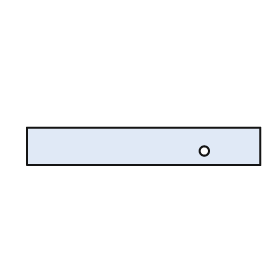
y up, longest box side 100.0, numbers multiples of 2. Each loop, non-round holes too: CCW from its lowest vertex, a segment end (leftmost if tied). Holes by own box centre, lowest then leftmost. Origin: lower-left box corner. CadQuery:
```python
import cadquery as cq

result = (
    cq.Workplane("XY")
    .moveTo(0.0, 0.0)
    .lineTo(100.0, 0.0)
    .lineTo(100.0, 16.0)
    .lineTo(0.0, 16.0)
    .close()
    .moveTo(76.0, 6.0)
    .circle(2.0)
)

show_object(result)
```